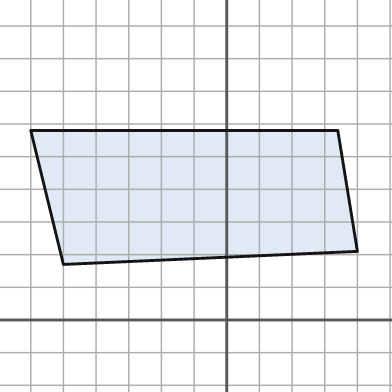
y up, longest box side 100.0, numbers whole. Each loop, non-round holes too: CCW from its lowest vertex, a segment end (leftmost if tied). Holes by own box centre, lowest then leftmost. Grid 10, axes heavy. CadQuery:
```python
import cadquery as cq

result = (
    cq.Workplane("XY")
    .moveTo(-50.0, 17.0)
    .lineTo(40.0, 21.0)
    .lineTo(34.0, 58.0)
    .lineTo(-60.0, 58.0)
    .close()
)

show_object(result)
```